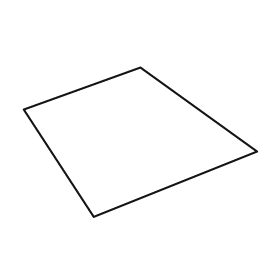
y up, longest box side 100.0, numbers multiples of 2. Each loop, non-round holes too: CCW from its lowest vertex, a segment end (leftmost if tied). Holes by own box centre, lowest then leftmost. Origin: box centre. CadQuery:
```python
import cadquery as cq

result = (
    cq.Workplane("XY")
    .moveTo(-20.0, -32.0)
    .lineTo(50.0, -4.0)
    .lineTo(0.0, 32.0)
    .lineTo(-50.0, 14.0)
    .close()
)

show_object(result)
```